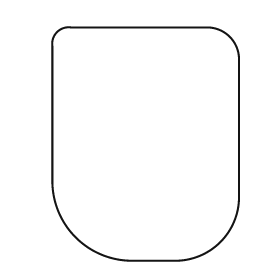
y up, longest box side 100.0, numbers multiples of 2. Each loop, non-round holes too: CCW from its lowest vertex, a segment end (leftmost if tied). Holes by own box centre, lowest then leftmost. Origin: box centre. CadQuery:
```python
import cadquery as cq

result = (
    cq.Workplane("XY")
    .moveTo(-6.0, -50.0)
    .lineTo(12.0, -50.0)
    .threePointArc((32.0, -42.0), (40.0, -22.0))
    .lineTo(40.0, 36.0)
    .threePointArc((36.0, 46.0), (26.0, 50.0))
    .lineTo(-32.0, 50.0)
    .threePointArc((-38.0, 48.0), (-40.0, 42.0))
    .lineTo(-40.0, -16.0)
    .threePointArc((-30.0, -40.0), (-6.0, -50.0))
    .close()
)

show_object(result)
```